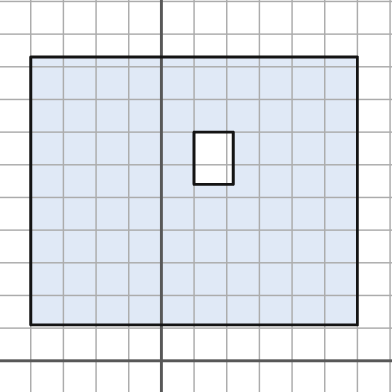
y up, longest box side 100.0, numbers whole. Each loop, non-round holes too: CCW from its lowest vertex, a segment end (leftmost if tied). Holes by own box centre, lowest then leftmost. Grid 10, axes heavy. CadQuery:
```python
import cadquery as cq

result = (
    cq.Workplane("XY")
    .moveTo(-40.0, 11.0)
    .lineTo(60.0, 11.0)
    .lineTo(60.0, 93.0)
    .lineTo(-40.0, 93.0)
    .close()
    .moveTo(10.0, 54.0)
    .lineTo(22.0, 54.0)
    .lineTo(22.0, 70.0)
    .lineTo(10.0, 70.0)
    .close()
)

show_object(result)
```